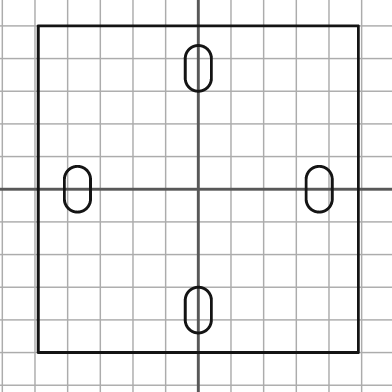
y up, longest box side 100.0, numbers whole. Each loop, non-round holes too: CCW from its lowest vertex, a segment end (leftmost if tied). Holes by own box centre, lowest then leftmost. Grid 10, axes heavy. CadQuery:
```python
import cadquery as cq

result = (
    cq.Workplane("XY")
    .moveTo(-49.0, -50.0)
    .lineTo(49.0, -50.0)
    .lineTo(49.0, 50.0)
    .lineTo(-49.0, 50.0)
    .close()
    .moveTo(-4.0, -40.0)
    .threePointArc((0.0, -44.0), (4.0, -40.0))
    .lineTo(4.0, -34.0)
    .threePointArc((0.0, -30.0), (-4.0, -34.0))
    .close()
    .moveTo(-41.0, -3.0)
    .threePointArc((-37.0, -7.0), (-33.0, -3.0))
    .lineTo(-33.0, 3.0)
    .threePointArc((-37.0, 7.0), (-41.0, 3.0))
    .close()
    .moveTo(33.0, -3.0)
    .threePointArc((37.0, -7.0), (41.0, -3.0))
    .lineTo(41.0, 3.0)
    .threePointArc((37.0, 7.0), (33.0, 3.0))
    .close()
    .moveTo(-4.0, 34.0)
    .threePointArc((0.0, 30.0), (4.0, 34.0))
    .lineTo(4.0, 40.0)
    .threePointArc((0.0, 44.0), (-4.0, 40.0))
    .close()
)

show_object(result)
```